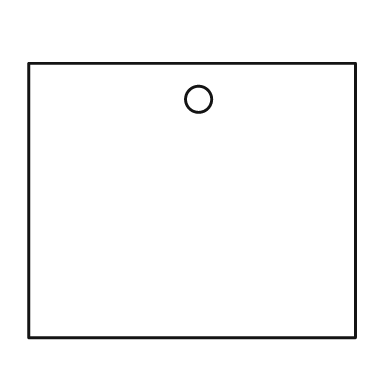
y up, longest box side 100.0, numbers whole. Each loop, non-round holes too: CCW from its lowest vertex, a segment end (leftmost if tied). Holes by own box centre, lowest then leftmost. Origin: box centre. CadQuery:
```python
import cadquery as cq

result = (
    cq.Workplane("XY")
    .moveTo(-50.0, -42.0)
    .lineTo(50.0, -42.0)
    .lineTo(50.0, 42.0)
    .lineTo(-50.0, 42.0)
    .close()
    .moveTo(2.0, 31.0)
    .circle(4.0)
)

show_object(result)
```